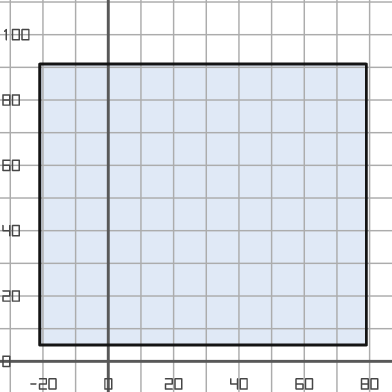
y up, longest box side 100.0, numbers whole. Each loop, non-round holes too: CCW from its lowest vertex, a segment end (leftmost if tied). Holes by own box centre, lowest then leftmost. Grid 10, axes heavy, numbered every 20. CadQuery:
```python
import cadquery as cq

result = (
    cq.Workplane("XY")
    .moveTo(-21.0, 5.0)
    .lineTo(79.0, 5.0)
    .lineTo(79.0, 91.0)
    .lineTo(-21.0, 91.0)
    .close()
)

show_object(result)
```